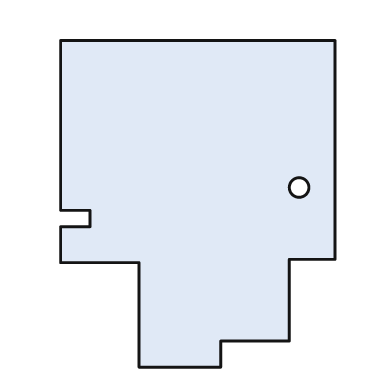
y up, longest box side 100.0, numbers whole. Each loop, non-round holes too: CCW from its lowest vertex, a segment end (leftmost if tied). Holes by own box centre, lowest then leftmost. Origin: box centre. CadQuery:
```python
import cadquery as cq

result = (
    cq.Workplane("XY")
    .moveTo(-18.0, -50.0)
    .lineTo(7.0, -50.0)
    .lineTo(7.0, -42.0)
    .lineTo(28.0, -42.0)
    .lineTo(28.0, -17.0)
    .lineTo(42.0, -17.0)
    .lineTo(42.0, 50.0)
    .lineTo(-42.0, 50.0)
    .lineTo(-42.0, -2.0)
    .lineTo(-33.0, -2.0)
    .lineTo(-33.0, -7.0)
    .lineTo(-42.0, -7.0)
    .lineTo(-42.0, -18.0)
    .lineTo(-18.0, -18.0)
    .close()
    .moveTo(31.0, 5.0)
    .circle(3.0)
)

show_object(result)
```